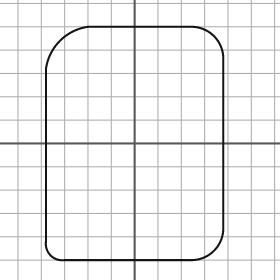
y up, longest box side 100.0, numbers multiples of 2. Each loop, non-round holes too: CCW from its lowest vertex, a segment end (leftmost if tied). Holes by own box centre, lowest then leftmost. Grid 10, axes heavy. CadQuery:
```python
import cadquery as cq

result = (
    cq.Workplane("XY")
    .moveTo(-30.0, -50.0)
    .lineTo(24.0, -50.0)
    .threePointArc((34.0, -46.0), (38.0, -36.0))
    .lineTo(38.0, 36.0)
    .threePointArc((34.0, 46.0), (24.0, 50.0))
    .lineTo(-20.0, 50.0)
    .threePointArc((-32.0, 44.0), (-38.0, 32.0))
    .lineTo(-38.0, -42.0)
    .threePointArc((-36.0, -48.0), (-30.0, -50.0))
    .close()
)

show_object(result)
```